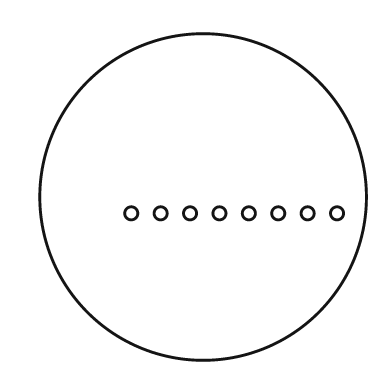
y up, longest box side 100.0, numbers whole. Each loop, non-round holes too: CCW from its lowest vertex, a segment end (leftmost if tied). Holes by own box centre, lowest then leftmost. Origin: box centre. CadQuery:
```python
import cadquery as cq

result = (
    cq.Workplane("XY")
    .moveTo(0.0, 0.0)
    .circle(50.0)
    .moveTo(-22.0, -5.0)
    .circle(2.0)
    .moveTo(-13.0, -5.0)
    .circle(2.0)
    .moveTo(-4.0, -5.0)
    .circle(2.0)
    .moveTo(5.0, -5.0)
    .circle(2.0)
    .moveTo(14.0, -5.0)
    .circle(2.0)
    .moveTo(23.0, -5.0)
    .circle(2.0)
    .moveTo(32.0, -5.0)
    .circle(2.0)
    .moveTo(41.0, -5.0)
    .circle(2.0)
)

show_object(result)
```